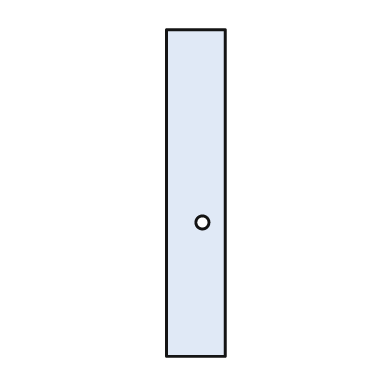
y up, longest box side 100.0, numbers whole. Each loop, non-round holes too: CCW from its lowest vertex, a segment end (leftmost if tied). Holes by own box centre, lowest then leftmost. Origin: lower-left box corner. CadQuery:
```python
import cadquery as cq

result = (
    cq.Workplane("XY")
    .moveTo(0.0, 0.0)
    .lineTo(18.0, 0.0)
    .lineTo(18.0, 100.0)
    .lineTo(0.0, 100.0)
    .close()
    .moveTo(11.0, 41.0)
    .circle(2.0)
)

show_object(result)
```